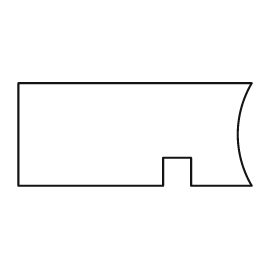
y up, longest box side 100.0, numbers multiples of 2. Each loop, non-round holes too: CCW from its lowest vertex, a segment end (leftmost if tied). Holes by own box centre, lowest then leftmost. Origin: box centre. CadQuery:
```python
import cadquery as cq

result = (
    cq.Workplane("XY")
    .moveTo(-50.0, -22.0)
    .lineTo(12.0, -22.0)
    .lineTo(12.0, -10.0)
    .lineTo(24.0, -10.0)
    .lineTo(24.0, -22.0)
    .lineTo(50.0, -22.0)
    .threePointArc((44.0, 0.0), (50.0, 22.0))
    .lineTo(-50.0, 22.0)
    .close()
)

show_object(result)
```